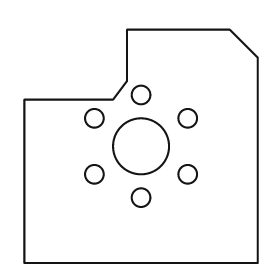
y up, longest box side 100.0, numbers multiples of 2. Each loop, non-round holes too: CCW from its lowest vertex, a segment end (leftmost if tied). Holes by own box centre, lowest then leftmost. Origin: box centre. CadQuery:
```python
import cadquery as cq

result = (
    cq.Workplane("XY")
    .moveTo(-50.0, -50.0)
    .lineTo(50.0, -50.0)
    .lineTo(50.0, 38.0)
    .lineTo(38.0, 50.0)
    .lineTo(-6.0, 50.0)
    .lineTo(-6.0, 28.0)
    .lineTo(-12.0, 20.0)
    .lineTo(-50.0, 20.0)
    .close()
    .moveTo(0.0, -22.0)
    .circle(4.0)
    .moveTo(-20.0, -12.0)
    .circle(4.0)
    .moveTo(20.0, -12.0)
    .circle(4.0)
    .moveTo(0.0, 0.0)
    .circle(12.0)
    .moveTo(-20.0, 12.0)
    .circle(4.0)
    .moveTo(20.0, 12.0)
    .circle(4.0)
    .moveTo(0.0, 22.0)
    .circle(4.0)
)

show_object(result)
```